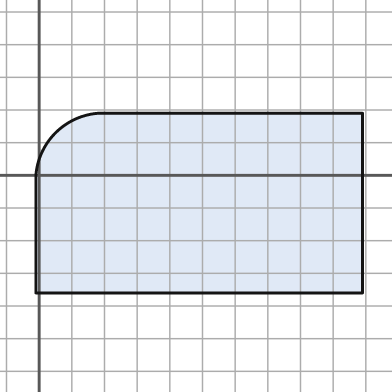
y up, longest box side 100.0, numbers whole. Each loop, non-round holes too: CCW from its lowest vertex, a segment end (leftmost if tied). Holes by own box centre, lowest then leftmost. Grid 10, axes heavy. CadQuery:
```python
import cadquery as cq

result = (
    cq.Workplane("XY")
    .moveTo(-1.0, -36.0)
    .lineTo(99.0, -36.0)
    .lineTo(99.0, 19.0)
    .lineTo(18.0, 19.0)
    .threePointArc((5.0, 13.0), (-1.0, 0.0))
    .close()
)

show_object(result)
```